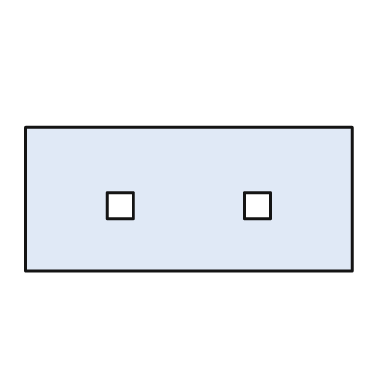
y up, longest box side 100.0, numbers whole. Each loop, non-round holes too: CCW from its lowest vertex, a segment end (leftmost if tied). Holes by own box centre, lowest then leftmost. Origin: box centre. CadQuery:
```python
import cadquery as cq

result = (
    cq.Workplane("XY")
    .moveTo(-50.0, -22.0)
    .lineTo(50.0, -22.0)
    .lineTo(50.0, 22.0)
    .lineTo(-50.0, 22.0)
    .close()
    .moveTo(-25.0, -6.0)
    .lineTo(-17.0, -6.0)
    .lineTo(-17.0, 2.0)
    .lineTo(-25.0, 2.0)
    .close()
    .moveTo(17.0, -6.0)
    .lineTo(25.0, -6.0)
    .lineTo(25.0, 2.0)
    .lineTo(17.0, 2.0)
    .close()
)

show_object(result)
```